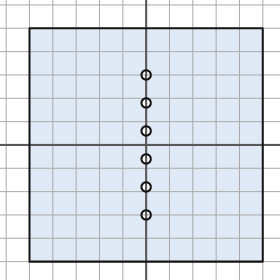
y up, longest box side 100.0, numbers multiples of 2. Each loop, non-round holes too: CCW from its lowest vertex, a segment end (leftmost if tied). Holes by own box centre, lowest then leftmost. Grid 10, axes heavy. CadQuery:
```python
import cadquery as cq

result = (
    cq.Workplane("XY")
    .moveTo(-50.0, -50.0)
    .lineTo(50.0, -50.0)
    .lineTo(50.0, 50.0)
    .lineTo(-50.0, 50.0)
    .close()
    .moveTo(0.0, -30.0)
    .circle(2.0)
    .moveTo(0.0, -18.0)
    .circle(2.0)
    .moveTo(0.0, -6.0)
    .circle(2.0)
    .moveTo(0.0, 6.0)
    .circle(2.0)
    .moveTo(0.0, 18.0)
    .circle(2.0)
    .moveTo(0.0, 30.0)
    .circle(2.0)
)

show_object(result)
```